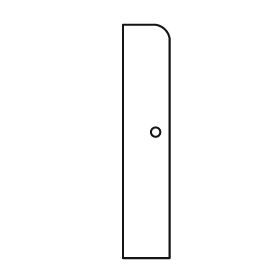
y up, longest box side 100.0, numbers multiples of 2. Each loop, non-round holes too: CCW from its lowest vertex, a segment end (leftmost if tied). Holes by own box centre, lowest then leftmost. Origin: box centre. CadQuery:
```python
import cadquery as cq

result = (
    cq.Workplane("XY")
    .moveTo(-10.0, -50.0)
    .lineTo(10.0, -50.0)
    .lineTo(10.0, 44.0)
    .threePointArc((8.0, 48.0), (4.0, 50.0))
    .lineTo(-10.0, 50.0)
    .close()
    .moveTo(4.0, 4.0)
    .circle(2.0)
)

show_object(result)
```